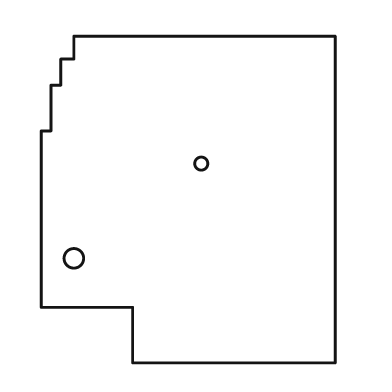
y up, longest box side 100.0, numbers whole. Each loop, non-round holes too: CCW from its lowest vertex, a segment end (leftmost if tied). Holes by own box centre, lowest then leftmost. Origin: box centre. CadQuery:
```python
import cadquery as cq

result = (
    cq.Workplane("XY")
    .moveTo(-17.0, -50.0)
    .lineTo(45.0, -50.0)
    .lineTo(45.0, 50.0)
    .lineTo(-35.0, 50.0)
    .lineTo(-35.0, 43.0)
    .lineTo(-39.0, 43.0)
    .lineTo(-39.0, 35.0)
    .lineTo(-42.0, 35.0)
    .lineTo(-42.0, 21.0)
    .lineTo(-45.0, 21.0)
    .lineTo(-45.0, -33.0)
    .lineTo(-17.0, -33.0)
    .close()
    .moveTo(-35.0, -18.0)
    .circle(3.0)
    .moveTo(4.0, 11.0)
    .circle(2.0)
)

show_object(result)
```